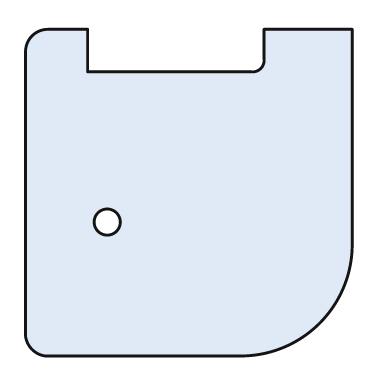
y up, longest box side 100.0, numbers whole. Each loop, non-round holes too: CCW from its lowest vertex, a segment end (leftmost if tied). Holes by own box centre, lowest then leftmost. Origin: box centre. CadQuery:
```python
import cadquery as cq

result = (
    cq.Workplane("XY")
    .moveTo(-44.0, -50.0)
    .lineTo(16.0, -50.0)
    .threePointArc((40.0, -40.0), (50.0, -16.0))
    .lineTo(50.0, 50.0)
    .lineTo(23.0, 50.0)
    .lineTo(23.0, 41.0)
    .threePointArc((22.0, 38.0), (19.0, 37.0))
    .lineTo(-31.0, 37.0)
    .lineTo(-31.0, 50.0)
    .lineTo(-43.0, 50.0)
    .threePointArc((-48.0, 48.0), (-50.0, 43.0))
    .lineTo(-50.0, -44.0)
    .threePointArc((-48.0, -48.0), (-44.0, -50.0))
    .close()
    .moveTo(-25.0, -9.0)
    .circle(4.0)
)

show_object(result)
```